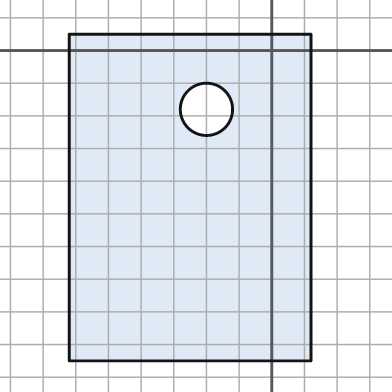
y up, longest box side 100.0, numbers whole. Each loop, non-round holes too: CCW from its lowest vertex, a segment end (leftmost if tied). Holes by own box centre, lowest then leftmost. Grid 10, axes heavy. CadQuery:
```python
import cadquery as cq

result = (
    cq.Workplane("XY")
    .moveTo(-62.0, -95.0)
    .lineTo(12.0, -95.0)
    .lineTo(12.0, 5.0)
    .lineTo(-62.0, 5.0)
    .close()
    .moveTo(-20.0, -18.0)
    .circle(8.0)
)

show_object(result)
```